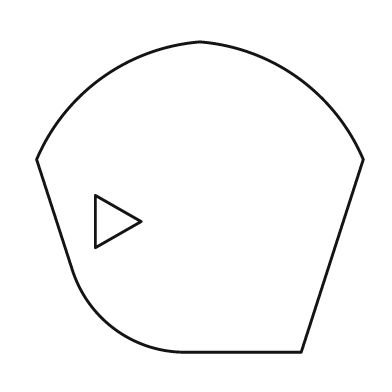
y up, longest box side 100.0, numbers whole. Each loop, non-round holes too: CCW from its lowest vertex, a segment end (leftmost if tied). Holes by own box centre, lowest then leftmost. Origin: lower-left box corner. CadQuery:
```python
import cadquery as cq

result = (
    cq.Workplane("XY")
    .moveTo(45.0, 0.0)
    .lineTo(81.0, 0.0)
    .lineTo(100.0, 59.0)
    .threePointArc((80.0, 84.0), (50.0, 95.0))
    .threePointArc((20.0, 84.0), (0.0, 59.0))
    .lineTo(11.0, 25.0)
    .threePointArc((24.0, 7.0), (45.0, 0.0))
    .close()
    .moveTo(18.0, 32.0)
    .lineTo(32.0, 40.0)
    .lineTo(18.0, 48.0)
    .close()
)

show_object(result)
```